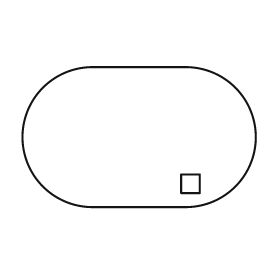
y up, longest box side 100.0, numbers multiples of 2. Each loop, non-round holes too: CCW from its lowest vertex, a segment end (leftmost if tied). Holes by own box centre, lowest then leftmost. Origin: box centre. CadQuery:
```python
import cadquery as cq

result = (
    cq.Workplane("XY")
    .moveTo(-20.0, -30.0)
    .lineTo(20.0, -30.0)
    .threePointArc((50.0, 0.0), (20.0, 30.0))
    .lineTo(-20.0, 30.0)
    .threePointArc((-50.0, 0.0), (-20.0, -30.0))
    .close()
    .moveTo(18.0, -24.0)
    .lineTo(26.0, -24.0)
    .lineTo(26.0, -16.0)
    .lineTo(18.0, -16.0)
    .close()
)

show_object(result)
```